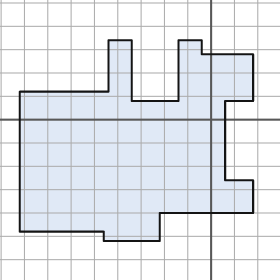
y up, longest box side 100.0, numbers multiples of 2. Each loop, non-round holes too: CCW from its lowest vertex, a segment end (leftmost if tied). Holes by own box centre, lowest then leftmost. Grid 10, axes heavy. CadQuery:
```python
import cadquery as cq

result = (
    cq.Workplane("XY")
    .moveTo(-46.0, -52.0)
    .lineTo(-22.0, -52.0)
    .lineTo(-22.0, -40.0)
    .lineTo(18.0, -40.0)
    .lineTo(18.0, -26.0)
    .lineTo(6.0, -26.0)
    .lineTo(6.0, 8.0)
    .lineTo(18.0, 8.0)
    .lineTo(18.0, 28.0)
    .lineTo(-4.0, 28.0)
    .lineTo(-4.0, 34.0)
    .lineTo(-14.0, 34.0)
    .lineTo(-14.0, 8.0)
    .lineTo(-34.0, 8.0)
    .lineTo(-34.0, 34.0)
    .lineTo(-44.0, 34.0)
    .lineTo(-44.0, 12.0)
    .lineTo(-82.0, 12.0)
    .lineTo(-82.0, -48.0)
    .lineTo(-46.0, -48.0)
    .close()
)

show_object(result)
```